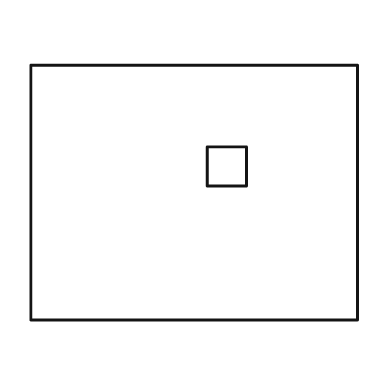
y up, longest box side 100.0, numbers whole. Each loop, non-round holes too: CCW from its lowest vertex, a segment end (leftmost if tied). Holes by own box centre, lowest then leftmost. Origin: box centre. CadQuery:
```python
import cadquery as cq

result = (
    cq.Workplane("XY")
    .moveTo(-50.0, -39.0)
    .lineTo(50.0, -39.0)
    .lineTo(50.0, 39.0)
    .lineTo(-50.0, 39.0)
    .close()
    .moveTo(4.0, 2.0)
    .lineTo(16.0, 2.0)
    .lineTo(16.0, 14.0)
    .lineTo(4.0, 14.0)
    .close()
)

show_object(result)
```